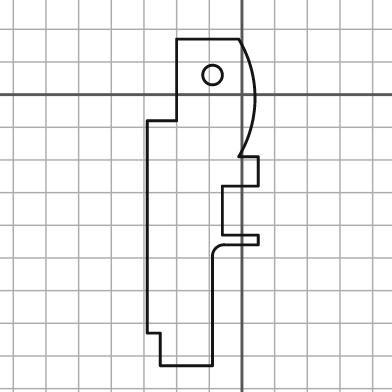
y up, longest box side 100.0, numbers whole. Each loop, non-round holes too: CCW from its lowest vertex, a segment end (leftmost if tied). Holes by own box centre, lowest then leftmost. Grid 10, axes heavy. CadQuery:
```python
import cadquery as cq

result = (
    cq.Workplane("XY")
    .moveTo(-25.0, -83.0)
    .lineTo(-9.0, -83.0)
    .lineTo(-9.0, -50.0)
    .threePointArc((-8.0, -47.0), (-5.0, -46.0))
    .lineTo(5.0, -46.0)
    .lineTo(5.0, -43.0)
    .lineTo(-6.0, -43.0)
    .lineTo(-6.0, -28.0)
    .lineTo(5.0, -28.0)
    .lineTo(5.0, -19.0)
    .lineTo(-1.0, -19.0)
    .threePointArc((4.0, -1.0), (-1.0, 17.0))
    .lineTo(-20.0, 17.0)
    .lineTo(-20.0, -8.0)
    .lineTo(-29.0, -8.0)
    .lineTo(-29.0, -73.0)
    .lineTo(-25.0, -73.0)
    .close()
    .moveTo(-9.0, 6.0)
    .circle(3.0)
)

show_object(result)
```